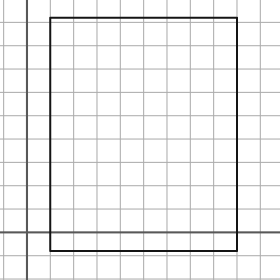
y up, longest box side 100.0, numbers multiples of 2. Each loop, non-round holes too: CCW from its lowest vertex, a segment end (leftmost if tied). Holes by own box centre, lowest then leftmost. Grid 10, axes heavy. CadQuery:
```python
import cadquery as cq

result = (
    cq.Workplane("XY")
    .moveTo(10.0, -8.0)
    .lineTo(90.0, -8.0)
    .lineTo(90.0, 92.0)
    .lineTo(10.0, 92.0)
    .close()
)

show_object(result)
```